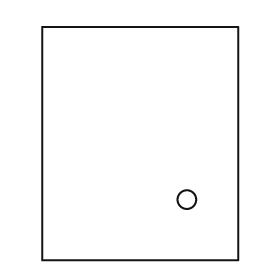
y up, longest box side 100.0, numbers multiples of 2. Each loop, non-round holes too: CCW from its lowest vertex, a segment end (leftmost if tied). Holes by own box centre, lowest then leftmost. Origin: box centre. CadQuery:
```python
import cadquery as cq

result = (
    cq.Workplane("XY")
    .moveTo(-42.0, -50.0)
    .lineTo(42.0, -50.0)
    .lineTo(42.0, 50.0)
    .lineTo(-42.0, 50.0)
    .close()
    .moveTo(20.0, -24.0)
    .circle(4.0)
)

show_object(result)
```